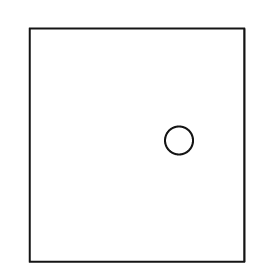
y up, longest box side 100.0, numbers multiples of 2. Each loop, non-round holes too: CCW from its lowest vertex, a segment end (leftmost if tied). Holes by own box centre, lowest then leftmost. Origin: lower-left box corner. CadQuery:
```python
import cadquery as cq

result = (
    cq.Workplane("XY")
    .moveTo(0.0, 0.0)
    .lineTo(92.0, 0.0)
    .lineTo(92.0, 100.0)
    .lineTo(0.0, 100.0)
    .close()
    .moveTo(64.0, 52.0)
    .circle(6.0)
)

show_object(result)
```